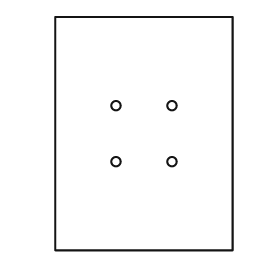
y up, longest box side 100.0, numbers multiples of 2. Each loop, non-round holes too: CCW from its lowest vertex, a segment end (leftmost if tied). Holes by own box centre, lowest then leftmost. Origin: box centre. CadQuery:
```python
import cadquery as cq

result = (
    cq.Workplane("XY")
    .moveTo(-38.0, -50.0)
    .lineTo(38.0, -50.0)
    .lineTo(38.0, 50.0)
    .lineTo(-38.0, 50.0)
    .close()
    .moveTo(-12.0, -12.0)
    .circle(2.0)
    .moveTo(12.0, -12.0)
    .circle(2.0)
    .moveTo(-12.0, 12.0)
    .circle(2.0)
    .moveTo(12.0, 12.0)
    .circle(2.0)
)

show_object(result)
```